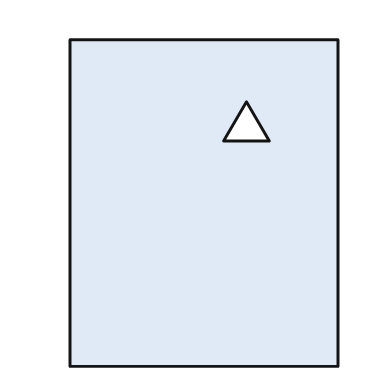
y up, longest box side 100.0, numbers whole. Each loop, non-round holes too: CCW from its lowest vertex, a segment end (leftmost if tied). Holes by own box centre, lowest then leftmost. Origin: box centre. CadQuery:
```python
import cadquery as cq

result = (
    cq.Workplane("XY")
    .moveTo(-41.0, -50.0)
    .lineTo(41.0, -50.0)
    .lineTo(41.0, 50.0)
    .lineTo(-41.0, 50.0)
    .close()
    .moveTo(6.0, 19.0)
    .lineTo(20.0, 19.0)
    .lineTo(13.0, 31.0)
    .close()
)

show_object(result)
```